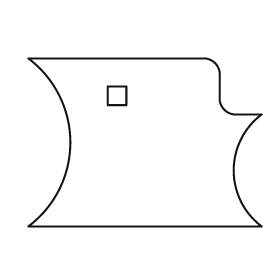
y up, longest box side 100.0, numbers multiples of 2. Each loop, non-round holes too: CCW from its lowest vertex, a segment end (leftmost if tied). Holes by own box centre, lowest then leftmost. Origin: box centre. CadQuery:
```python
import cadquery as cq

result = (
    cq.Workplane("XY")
    .moveTo(-50.0, -36.0)
    .lineTo(50.0, -36.0)
    .threePointArc((38.0, -12.0), (50.0, 12.0))
    .lineTo(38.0, 12.0)
    .threePointArc((34.0, 14.0), (32.0, 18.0))
    .lineTo(32.0, 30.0)
    .threePointArc((30.0, 34.0), (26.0, 36.0))
    .lineTo(-50.0, 36.0)
    .threePointArc((-32.0, 0.0), (-50.0, -36.0))
    .close()
    .moveTo(-16.0, 16.0)
    .lineTo(-8.0, 16.0)
    .lineTo(-8.0, 24.0)
    .lineTo(-16.0, 24.0)
    .close()
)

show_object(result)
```